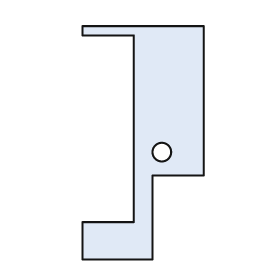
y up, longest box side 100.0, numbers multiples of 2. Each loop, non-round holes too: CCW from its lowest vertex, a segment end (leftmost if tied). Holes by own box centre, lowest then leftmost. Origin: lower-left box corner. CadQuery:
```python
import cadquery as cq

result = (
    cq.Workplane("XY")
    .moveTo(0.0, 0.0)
    .lineTo(30.0, 0.0)
    .lineTo(30.0, 36.0)
    .lineTo(52.0, 36.0)
    .lineTo(52.0, 100.0)
    .lineTo(0.0, 100.0)
    .lineTo(0.0, 96.0)
    .lineTo(22.0, 96.0)
    .lineTo(22.0, 16.0)
    .lineTo(0.0, 16.0)
    .close()
    .moveTo(34.0, 46.0)
    .circle(4.0)
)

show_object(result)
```